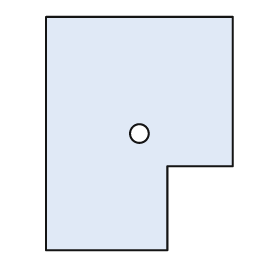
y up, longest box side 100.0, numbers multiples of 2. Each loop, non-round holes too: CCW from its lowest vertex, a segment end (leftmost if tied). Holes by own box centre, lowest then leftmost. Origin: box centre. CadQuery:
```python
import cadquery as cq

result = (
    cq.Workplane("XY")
    .moveTo(-40.0, -50.0)
    .lineTo(12.0, -50.0)
    .lineTo(12.0, -14.0)
    .lineTo(40.0, -14.0)
    .lineTo(40.0, 50.0)
    .lineTo(-40.0, 50.0)
    .close()
    .moveTo(0.0, 0.0)
    .circle(4.0)
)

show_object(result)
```